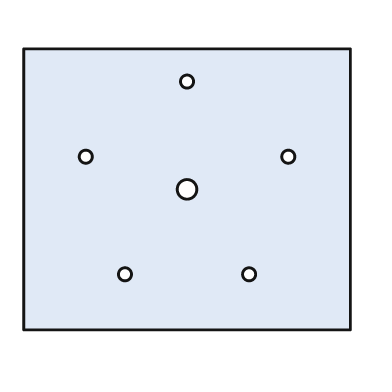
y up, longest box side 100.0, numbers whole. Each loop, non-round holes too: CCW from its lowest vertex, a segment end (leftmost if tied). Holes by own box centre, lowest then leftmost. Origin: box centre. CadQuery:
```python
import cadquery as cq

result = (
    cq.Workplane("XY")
    .moveTo(-50.0, -43.0)
    .lineTo(50.0, -43.0)
    .lineTo(50.0, 43.0)
    .lineTo(-50.0, 43.0)
    .close()
    .moveTo(-19.0, -26.0)
    .circle(2.0)
    .moveTo(19.0, -26.0)
    .circle(2.0)
    .moveTo(0.0, 0.0)
    .circle(3.0)
    .moveTo(-31.0, 10.0)
    .circle(2.0)
    .moveTo(31.0, 10.0)
    .circle(2.0)
    .moveTo(0.0, 33.0)
    .circle(2.0)
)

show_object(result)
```